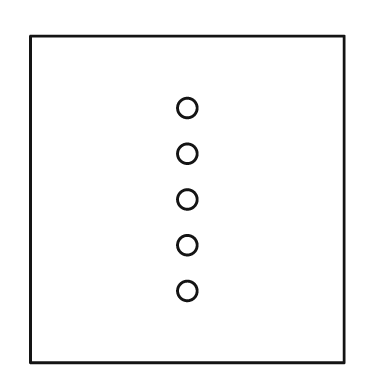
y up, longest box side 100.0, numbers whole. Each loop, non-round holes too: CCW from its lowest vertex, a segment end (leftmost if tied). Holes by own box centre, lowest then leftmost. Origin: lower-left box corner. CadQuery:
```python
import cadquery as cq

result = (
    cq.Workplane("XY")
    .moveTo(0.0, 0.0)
    .lineTo(96.0, 0.0)
    .lineTo(96.0, 100.0)
    .lineTo(0.0, 100.0)
    .close()
    .moveTo(48.0, 22.0)
    .circle(3.0)
    .moveTo(48.0, 36.0)
    .circle(3.0)
    .moveTo(48.0, 50.0)
    .circle(3.0)
    .moveTo(48.0, 64.0)
    .circle(3.0)
    .moveTo(48.0, 78.0)
    .circle(3.0)
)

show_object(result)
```